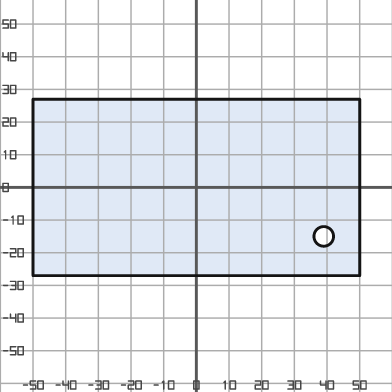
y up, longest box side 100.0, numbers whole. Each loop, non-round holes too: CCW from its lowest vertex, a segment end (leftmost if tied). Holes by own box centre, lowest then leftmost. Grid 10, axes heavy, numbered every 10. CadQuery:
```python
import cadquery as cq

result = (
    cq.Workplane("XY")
    .moveTo(-50.0, -27.0)
    .lineTo(50.0, -27.0)
    .lineTo(50.0, 27.0)
    .lineTo(-50.0, 27.0)
    .close()
    .moveTo(39.0, -15.0)
    .circle(3.0)
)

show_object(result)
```